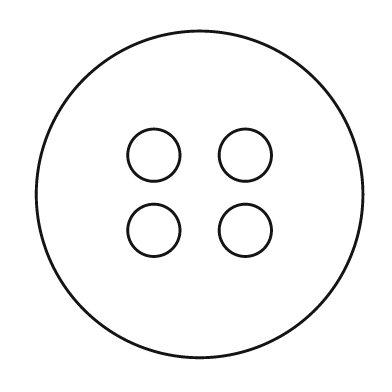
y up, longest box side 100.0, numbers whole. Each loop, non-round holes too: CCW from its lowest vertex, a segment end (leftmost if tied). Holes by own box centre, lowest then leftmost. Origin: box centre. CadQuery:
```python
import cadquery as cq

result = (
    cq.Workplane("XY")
    .moveTo(0.0, 0.0)
    .circle(50.0)
    .moveTo(-14.0, -11.0)
    .circle(8.0)
    .moveTo(14.0, -11.0)
    .circle(8.0)
    .moveTo(-14.0, 12.0)
    .circle(8.0)
    .moveTo(14.0, 12.0)
    .circle(8.0)
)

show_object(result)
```